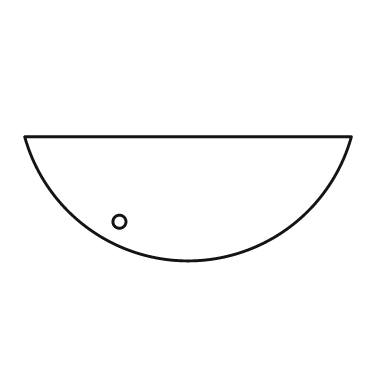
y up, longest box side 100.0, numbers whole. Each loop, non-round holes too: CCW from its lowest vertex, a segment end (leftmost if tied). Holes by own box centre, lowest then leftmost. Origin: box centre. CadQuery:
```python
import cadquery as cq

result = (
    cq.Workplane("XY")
    .moveTo(-50.0, 19.0)
    .threePointArc((0.0, -19.0), (50.0, 19.0))
    .close()
    .moveTo(-21.0, -7.0)
    .circle(2.0)
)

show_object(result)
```